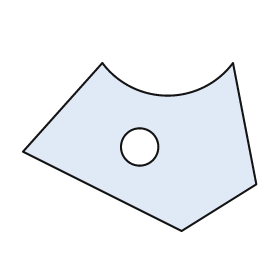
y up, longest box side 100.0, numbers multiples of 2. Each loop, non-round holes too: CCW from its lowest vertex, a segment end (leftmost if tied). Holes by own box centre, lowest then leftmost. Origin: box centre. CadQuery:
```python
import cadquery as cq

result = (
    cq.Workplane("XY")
    .moveTo(18.0, -36.0)
    .lineTo(50.0, -16.0)
    .lineTo(40.0, 36.0)
    .threePointArc((12.0, 22.0), (-16.0, 36.0))
    .lineTo(-50.0, -2.0)
    .close()
    .moveTo(0.0, 0.0)
    .circle(8.0)
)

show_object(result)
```